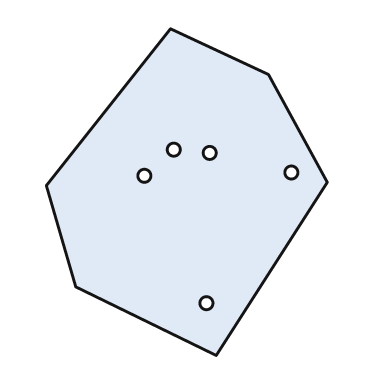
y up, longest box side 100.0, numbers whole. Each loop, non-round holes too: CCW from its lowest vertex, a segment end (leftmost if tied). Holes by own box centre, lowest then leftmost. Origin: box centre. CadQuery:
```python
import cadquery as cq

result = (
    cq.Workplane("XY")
    .moveTo(9.0, -50.0)
    .lineTo(43.0, 3.0)
    .lineTo(25.0, 36.0)
    .lineTo(-5.0, 50.0)
    .lineTo(-43.0, 2.0)
    .lineTo(-34.0, -29.0)
    .close()
    .moveTo(6.0, -34.0)
    .circle(2.0)
    .moveTo(-13.0, 5.0)
    .circle(2.0)
    .moveTo(32.0, 6.0)
    .circle(2.0)
    .moveTo(7.0, 12.0)
    .circle(2.0)
    .moveTo(-4.0, 13.0)
    .circle(2.0)
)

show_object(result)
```